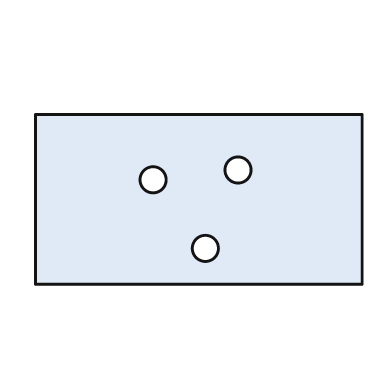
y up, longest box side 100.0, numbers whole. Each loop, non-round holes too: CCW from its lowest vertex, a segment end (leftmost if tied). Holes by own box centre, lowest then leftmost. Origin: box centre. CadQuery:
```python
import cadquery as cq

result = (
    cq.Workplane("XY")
    .moveTo(-50.0, -26.0)
    .lineTo(50.0, -26.0)
    .lineTo(50.0, 26.0)
    .lineTo(-50.0, 26.0)
    .close()
    .moveTo(2.0, -15.0)
    .circle(4.0)
    .moveTo(-14.0, 6.0)
    .circle(4.0)
    .moveTo(12.0, 9.0)
    .circle(4.0)
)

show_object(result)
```